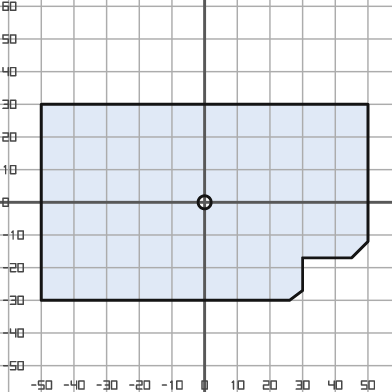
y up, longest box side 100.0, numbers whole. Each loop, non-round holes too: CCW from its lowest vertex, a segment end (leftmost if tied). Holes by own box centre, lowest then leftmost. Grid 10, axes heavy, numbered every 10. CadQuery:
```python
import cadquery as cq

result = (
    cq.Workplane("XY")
    .moveTo(-50.0, -30.0)
    .lineTo(26.0, -30.0)
    .lineTo(30.0, -27.0)
    .lineTo(30.0, -17.0)
    .lineTo(45.0, -17.0)
    .lineTo(50.0, -12.0)
    .lineTo(50.0, 30.0)
    .lineTo(-50.0, 30.0)
    .close()
    .moveTo(0.0, 0.0)
    .circle(2.0)
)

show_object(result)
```